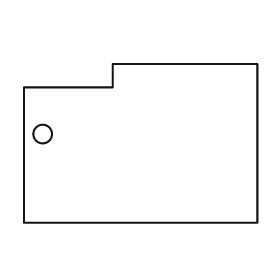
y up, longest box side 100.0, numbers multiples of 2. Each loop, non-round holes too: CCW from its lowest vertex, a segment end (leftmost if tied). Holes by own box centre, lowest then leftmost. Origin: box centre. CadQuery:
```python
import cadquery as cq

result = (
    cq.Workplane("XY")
    .moveTo(-50.0, -34.0)
    .lineTo(50.0, -34.0)
    .lineTo(50.0, 34.0)
    .lineTo(-12.0, 34.0)
    .lineTo(-12.0, 24.0)
    .lineTo(-50.0, 24.0)
    .close()
    .moveTo(-42.0, 4.0)
    .circle(4.0)
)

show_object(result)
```